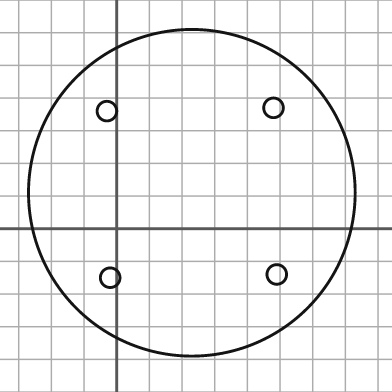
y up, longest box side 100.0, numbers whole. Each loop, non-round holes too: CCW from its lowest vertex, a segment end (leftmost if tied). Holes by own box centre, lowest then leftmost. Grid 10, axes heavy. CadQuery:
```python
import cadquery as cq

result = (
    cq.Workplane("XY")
    .moveTo(23.0, 11.0)
    .circle(50.0)
    .moveTo(-2.0, -15.0)
    .circle(3.0)
    .moveTo(49.0, -14.0)
    .circle(3.0)
    .moveTo(-3.0, 36.0)
    .circle(3.0)
    .moveTo(48.0, 37.0)
    .circle(3.0)
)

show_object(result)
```